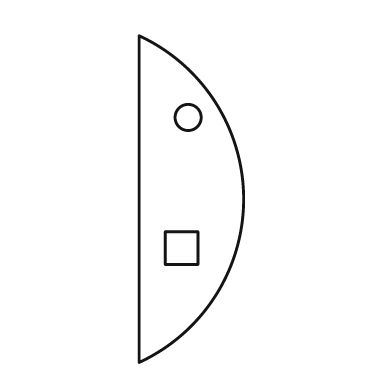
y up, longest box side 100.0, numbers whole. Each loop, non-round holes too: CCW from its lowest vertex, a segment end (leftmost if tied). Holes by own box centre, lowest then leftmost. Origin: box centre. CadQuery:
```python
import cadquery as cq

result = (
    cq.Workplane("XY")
    .moveTo(-16.0, -50.0)
    .threePointArc((16.0, 0.0), (-16.0, 50.0))
    .close()
    .moveTo(-8.0, -20.0)
    .lineTo(2.0, -20.0)
    .lineTo(2.0, -10.0)
    .lineTo(-8.0, -10.0)
    .close()
    .moveTo(-1.0, 25.0)
    .circle(4.0)
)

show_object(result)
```